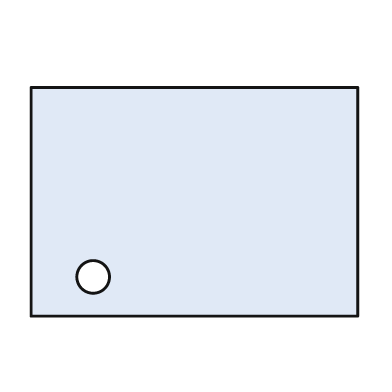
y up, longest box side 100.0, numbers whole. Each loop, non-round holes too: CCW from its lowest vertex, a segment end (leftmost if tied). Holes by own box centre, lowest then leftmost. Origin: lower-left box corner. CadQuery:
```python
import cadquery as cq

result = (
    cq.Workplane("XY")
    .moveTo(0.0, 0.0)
    .lineTo(100.0, 0.0)
    .lineTo(100.0, 70.0)
    .lineTo(0.0, 70.0)
    .close()
    .moveTo(19.0, 12.0)
    .circle(5.0)
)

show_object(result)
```